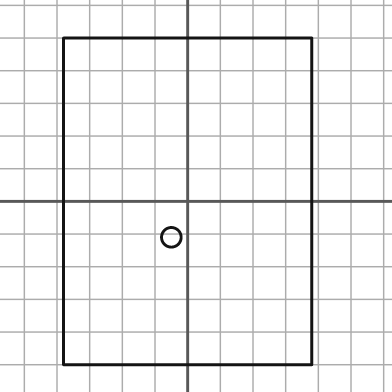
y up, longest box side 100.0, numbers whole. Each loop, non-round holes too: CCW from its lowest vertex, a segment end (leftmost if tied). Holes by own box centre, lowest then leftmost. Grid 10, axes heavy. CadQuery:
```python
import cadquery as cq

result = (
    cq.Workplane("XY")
    .moveTo(-38.0, -50.0)
    .lineTo(38.0, -50.0)
    .lineTo(38.0, 50.0)
    .lineTo(-38.0, 50.0)
    .close()
    .moveTo(-5.0, -11.0)
    .circle(3.0)
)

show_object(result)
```